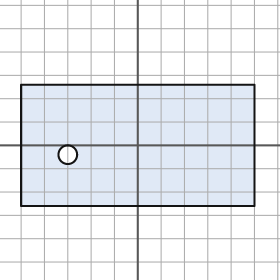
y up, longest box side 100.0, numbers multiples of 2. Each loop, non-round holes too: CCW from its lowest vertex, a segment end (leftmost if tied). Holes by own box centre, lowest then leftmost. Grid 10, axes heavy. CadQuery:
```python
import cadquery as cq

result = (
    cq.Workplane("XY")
    .moveTo(-50.0, -26.0)
    .lineTo(50.0, -26.0)
    .lineTo(50.0, 26.0)
    .lineTo(-50.0, 26.0)
    .close()
    .moveTo(-30.0, -4.0)
    .circle(4.0)
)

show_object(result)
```